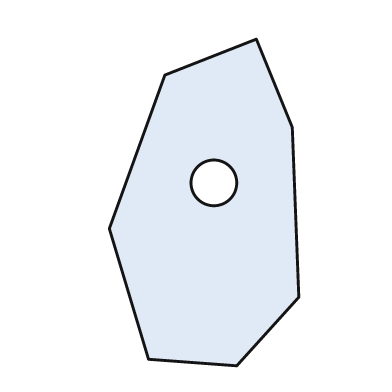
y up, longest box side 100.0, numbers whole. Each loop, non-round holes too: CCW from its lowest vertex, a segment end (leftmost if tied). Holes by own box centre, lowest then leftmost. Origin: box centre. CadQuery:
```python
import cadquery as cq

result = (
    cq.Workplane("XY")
    .moveTo(10.0, -50.0)
    .lineTo(29.0, -29.0)
    .lineTo(27.0, 23.0)
    .lineTo(16.0, 50.0)
    .lineTo(-12.0, 39.0)
    .lineTo(-29.0, -8.0)
    .lineTo(-17.0, -48.0)
    .close()
    .moveTo(3.0, 6.0)
    .circle(7.0)
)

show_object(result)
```